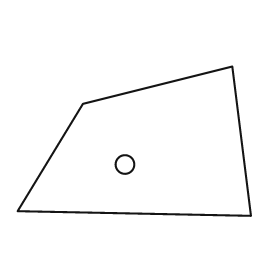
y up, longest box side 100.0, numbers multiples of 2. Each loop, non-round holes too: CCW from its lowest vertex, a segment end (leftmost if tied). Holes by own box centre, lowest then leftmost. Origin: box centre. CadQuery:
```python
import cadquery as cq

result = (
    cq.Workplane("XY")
    .moveTo(50.0, -32.0)
    .lineTo(42.0, 32.0)
    .lineTo(-22.0, 16.0)
    .lineTo(-50.0, -30.0)
    .close()
    .moveTo(-4.0, -10.0)
    .circle(4.0)
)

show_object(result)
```